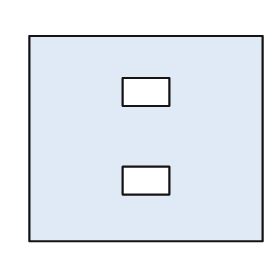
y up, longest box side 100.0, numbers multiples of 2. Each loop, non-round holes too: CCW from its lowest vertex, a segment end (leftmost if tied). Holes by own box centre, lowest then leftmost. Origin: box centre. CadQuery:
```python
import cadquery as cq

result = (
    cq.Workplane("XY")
    .moveTo(-50.0, -44.0)
    .lineTo(50.0, -44.0)
    .lineTo(50.0, 44.0)
    .lineTo(-50.0, 44.0)
    .close()
    .moveTo(-10.0, -24.0)
    .lineTo(10.0, -24.0)
    .lineTo(10.0, -12.0)
    .lineTo(-10.0, -12.0)
    .close()
    .moveTo(-10.0, 14.0)
    .lineTo(10.0, 14.0)
    .lineTo(10.0, 26.0)
    .lineTo(-10.0, 26.0)
    .close()
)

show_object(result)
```